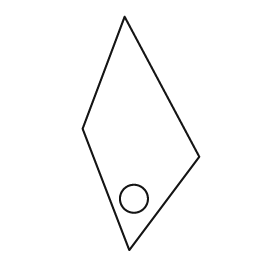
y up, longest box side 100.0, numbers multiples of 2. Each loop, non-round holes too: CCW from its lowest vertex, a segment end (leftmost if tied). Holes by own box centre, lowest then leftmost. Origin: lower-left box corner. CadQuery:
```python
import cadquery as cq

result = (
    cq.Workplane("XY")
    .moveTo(20.0, 0.0)
    .lineTo(50.0, 40.0)
    .lineTo(18.0, 100.0)
    .lineTo(0.0, 52.0)
    .close()
    .moveTo(22.0, 22.0)
    .circle(6.0)
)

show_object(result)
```